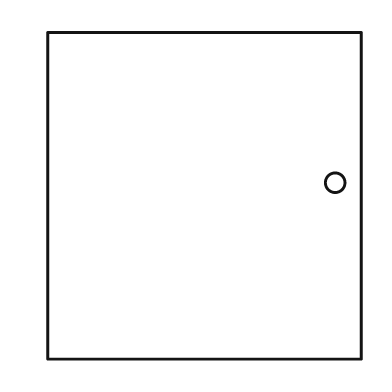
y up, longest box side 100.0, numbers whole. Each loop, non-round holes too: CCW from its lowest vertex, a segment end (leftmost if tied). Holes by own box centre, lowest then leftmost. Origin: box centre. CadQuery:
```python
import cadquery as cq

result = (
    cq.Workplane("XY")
    .moveTo(-48.0, -50.0)
    .lineTo(48.0, -50.0)
    .lineTo(48.0, 50.0)
    .lineTo(-48.0, 50.0)
    .close()
    .moveTo(40.0, 4.0)
    .circle(3.0)
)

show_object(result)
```